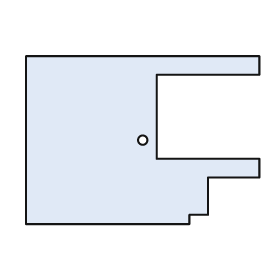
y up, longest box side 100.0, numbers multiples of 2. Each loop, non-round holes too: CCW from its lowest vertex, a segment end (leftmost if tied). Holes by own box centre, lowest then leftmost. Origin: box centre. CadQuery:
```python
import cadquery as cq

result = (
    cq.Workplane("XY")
    .moveTo(-50.0, -36.0)
    .lineTo(20.0, -36.0)
    .lineTo(20.0, -32.0)
    .lineTo(28.0, -32.0)
    .lineTo(28.0, -16.0)
    .lineTo(50.0, -16.0)
    .lineTo(50.0, -8.0)
    .lineTo(6.0, -8.0)
    .lineTo(6.0, 28.0)
    .lineTo(50.0, 28.0)
    .lineTo(50.0, 36.0)
    .lineTo(-50.0, 36.0)
    .close()
    .moveTo(0.0, 0.0)
    .circle(2.0)
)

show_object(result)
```